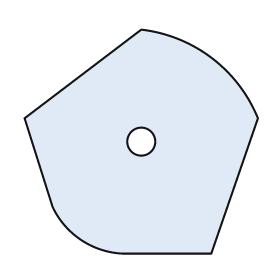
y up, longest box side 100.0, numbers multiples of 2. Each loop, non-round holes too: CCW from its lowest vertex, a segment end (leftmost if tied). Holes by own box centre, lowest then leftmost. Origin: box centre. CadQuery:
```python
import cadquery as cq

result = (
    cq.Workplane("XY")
    .moveTo(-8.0, -48.0)
    .lineTo(30.0, -48.0)
    .lineTo(50.0, 10.0)
    .threePointArc((30.0, 36.0), (0.0, 48.0))
    .lineTo(-50.0, 10.0)
    .lineTo(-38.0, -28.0)
    .threePointArc((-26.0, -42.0), (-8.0, -48.0))
    .close()
    .moveTo(0.0, 0.0)
    .circle(6.0)
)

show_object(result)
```